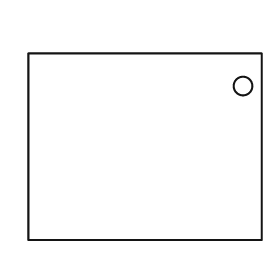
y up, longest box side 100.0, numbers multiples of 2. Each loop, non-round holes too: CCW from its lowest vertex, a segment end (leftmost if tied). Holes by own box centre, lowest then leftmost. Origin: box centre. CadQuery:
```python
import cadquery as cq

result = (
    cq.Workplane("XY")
    .moveTo(-50.0, -40.0)
    .lineTo(50.0, -40.0)
    .lineTo(50.0, 40.0)
    .lineTo(-50.0, 40.0)
    .close()
    .moveTo(42.0, 26.0)
    .circle(4.0)
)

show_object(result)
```